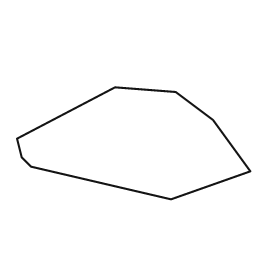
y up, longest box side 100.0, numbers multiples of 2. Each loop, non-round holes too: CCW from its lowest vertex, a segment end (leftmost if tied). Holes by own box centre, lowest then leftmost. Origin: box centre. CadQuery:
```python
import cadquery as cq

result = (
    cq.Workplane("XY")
    .moveTo(16.0, -24.0)
    .lineTo(50.0, -12.0)
    .lineTo(34.0, 10.0)
    .lineTo(18.0, 22.0)
    .lineTo(-8.0, 24.0)
    .lineTo(-50.0, 2.0)
    .lineTo(-48.0, -6.0)
    .lineTo(-44.0, -10.0)
    .close()
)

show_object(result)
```